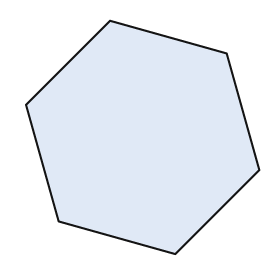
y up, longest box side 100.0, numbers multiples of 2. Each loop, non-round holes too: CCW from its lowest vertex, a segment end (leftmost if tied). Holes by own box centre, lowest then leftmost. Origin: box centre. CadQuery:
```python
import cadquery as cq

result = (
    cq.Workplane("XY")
    .moveTo(14.0, -50.0)
    .lineTo(50.0, -14.0)
    .lineTo(36.0, 36.0)
    .lineTo(-14.0, 50.0)
    .lineTo(-50.0, 14.0)
    .lineTo(-36.0, -36.0)
    .close()
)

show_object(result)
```